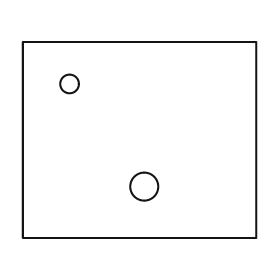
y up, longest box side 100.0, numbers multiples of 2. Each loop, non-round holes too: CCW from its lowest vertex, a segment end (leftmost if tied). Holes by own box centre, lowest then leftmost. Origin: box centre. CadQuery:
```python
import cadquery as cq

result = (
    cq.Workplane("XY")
    .moveTo(-50.0, -42.0)
    .lineTo(50.0, -42.0)
    .lineTo(50.0, 42.0)
    .lineTo(-50.0, 42.0)
    .close()
    .moveTo(2.0, -20.0)
    .circle(6.0)
    .moveTo(-30.0, 24.0)
    .circle(4.0)
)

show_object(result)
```